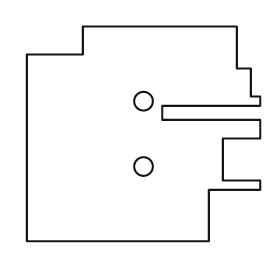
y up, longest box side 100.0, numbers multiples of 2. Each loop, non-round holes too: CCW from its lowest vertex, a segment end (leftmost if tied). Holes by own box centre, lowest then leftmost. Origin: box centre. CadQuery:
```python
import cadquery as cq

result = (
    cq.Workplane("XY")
    .moveTo(-50.0, -46.0)
    .lineTo(28.0, -46.0)
    .lineTo(28.0, -24.0)
    .lineTo(50.0, -24.0)
    .lineTo(50.0, -20.0)
    .lineTo(34.0, -20.0)
    .lineTo(34.0, -2.0)
    .lineTo(50.0, -2.0)
    .lineTo(50.0, 6.0)
    .lineTo(8.0, 6.0)
    .lineTo(8.0, 12.0)
    .lineTo(50.0, 12.0)
    .lineTo(50.0, 16.0)
    .lineTo(46.0, 16.0)
    .lineTo(46.0, 28.0)
    .lineTo(40.0, 28.0)
    .lineTo(40.0, 46.0)
    .lineTo(-26.0, 46.0)
    .lineTo(-26.0, 34.0)
    .lineTo(-50.0, 34.0)
    .close()
    .moveTo(0.0, -14.0)
    .circle(4.0)
    .moveTo(0.0, 14.0)
    .circle(4.0)
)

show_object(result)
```